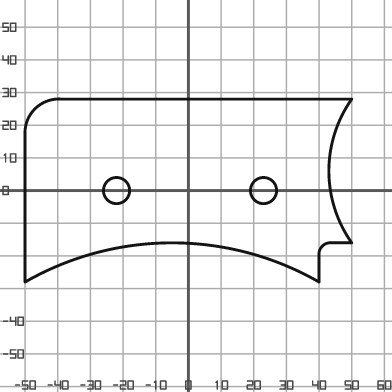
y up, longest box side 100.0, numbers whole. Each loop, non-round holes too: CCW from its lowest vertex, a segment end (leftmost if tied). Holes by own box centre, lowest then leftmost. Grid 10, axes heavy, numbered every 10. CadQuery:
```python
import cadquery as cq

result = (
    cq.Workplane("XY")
    .moveTo(-50.0, -28.0)
    .threePointArc((-5.0, -16.0), (40.0, -28.0))
    .lineTo(40.0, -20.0)
    .threePointArc((41.0, -17.0), (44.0, -16.0))
    .lineTo(50.0, -16.0)
    .threePointArc((43.0, 6.0), (50.0, 28.0))
    .lineTo(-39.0, 28.0)
    .threePointArc((-47.0, 25.0), (-50.0, 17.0))
    .close()
    .moveTo(-22.0, 0.0)
    .circle(4.0)
    .moveTo(23.0, 0.0)
    .circle(4.0)
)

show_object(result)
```